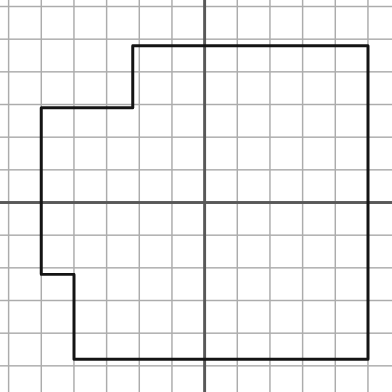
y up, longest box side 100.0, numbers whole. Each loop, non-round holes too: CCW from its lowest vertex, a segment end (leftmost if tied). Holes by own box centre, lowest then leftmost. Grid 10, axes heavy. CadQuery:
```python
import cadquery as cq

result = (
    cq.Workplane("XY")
    .moveTo(-40.0, -48.0)
    .lineTo(50.0, -48.0)
    .lineTo(50.0, 48.0)
    .lineTo(-22.0, 48.0)
    .lineTo(-22.0, 29.0)
    .lineTo(-50.0, 29.0)
    .lineTo(-50.0, -22.0)
    .lineTo(-40.0, -22.0)
    .close()
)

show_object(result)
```